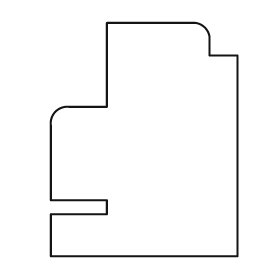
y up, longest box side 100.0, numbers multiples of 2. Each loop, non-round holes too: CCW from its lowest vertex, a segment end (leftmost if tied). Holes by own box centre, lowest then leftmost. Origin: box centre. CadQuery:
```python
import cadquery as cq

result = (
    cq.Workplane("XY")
    .moveTo(-40.0, -50.0)
    .lineTo(40.0, -50.0)
    .lineTo(40.0, 36.0)
    .lineTo(28.0, 36.0)
    .lineTo(28.0, 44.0)
    .threePointArc((26.0, 48.0), (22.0, 50.0))
    .lineTo(-16.0, 50.0)
    .lineTo(-16.0, 14.0)
    .lineTo(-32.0, 14.0)
    .threePointArc((-38.0, 12.0), (-40.0, 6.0))
    .lineTo(-40.0, -26.0)
    .lineTo(-16.0, -26.0)
    .lineTo(-16.0, -32.0)
    .lineTo(-40.0, -32.0)
    .close()
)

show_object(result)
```